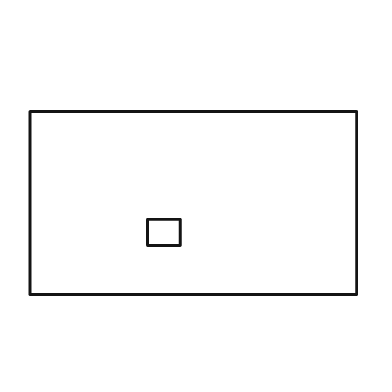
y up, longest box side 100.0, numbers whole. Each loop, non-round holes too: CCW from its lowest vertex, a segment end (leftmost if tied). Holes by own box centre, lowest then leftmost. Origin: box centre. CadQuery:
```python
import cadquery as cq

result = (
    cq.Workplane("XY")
    .moveTo(-50.0, -28.0)
    .lineTo(50.0, -28.0)
    .lineTo(50.0, 28.0)
    .lineTo(-50.0, 28.0)
    .close()
    .moveTo(-14.0, -13.0)
    .lineTo(-4.0, -13.0)
    .lineTo(-4.0, -5.0)
    .lineTo(-14.0, -5.0)
    .close()
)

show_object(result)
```